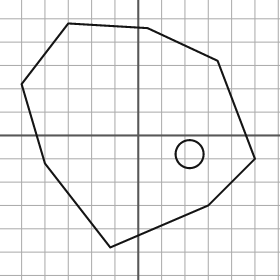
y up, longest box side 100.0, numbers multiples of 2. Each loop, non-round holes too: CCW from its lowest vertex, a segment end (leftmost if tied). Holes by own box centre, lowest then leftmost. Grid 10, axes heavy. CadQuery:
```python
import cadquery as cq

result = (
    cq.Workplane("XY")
    .moveTo(-12.0, -48.0)
    .lineTo(30.0, -30.0)
    .lineTo(50.0, -10.0)
    .lineTo(34.0, 32.0)
    .lineTo(4.0, 46.0)
    .lineTo(-30.0, 48.0)
    .lineTo(-50.0, 22.0)
    .lineTo(-40.0, -12.0)
    .close()
    .moveTo(22.0, -8.0)
    .circle(6.0)
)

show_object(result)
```